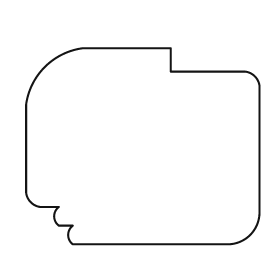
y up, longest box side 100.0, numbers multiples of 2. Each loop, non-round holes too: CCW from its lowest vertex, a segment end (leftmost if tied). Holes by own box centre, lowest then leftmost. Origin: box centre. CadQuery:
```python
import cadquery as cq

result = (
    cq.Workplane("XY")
    .moveTo(-30.0, -42.0)
    .lineTo(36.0, -42.0)
    .threePointArc((46.0, -38.0), (50.0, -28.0))
    .lineTo(50.0, 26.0)
    .threePointArc((48.0, 30.0), (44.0, 32.0))
    .lineTo(12.0, 32.0)
    .lineTo(12.0, 42.0)
    .lineTo(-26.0, 42.0)
    .threePointArc((-42.0, 34.0), (-50.0, 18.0))
    .lineTo(-50.0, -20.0)
    .threePointArc((-48.0, -24.0), (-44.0, -26.0))
    .lineTo(-36.0, -26.0)
    .threePointArc((-38.0, -30.0), (-36.0, -34.0))
    .lineTo(-30.0, -34.0)
    .threePointArc((-32.0, -38.0), (-30.0, -42.0))
    .close()
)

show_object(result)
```